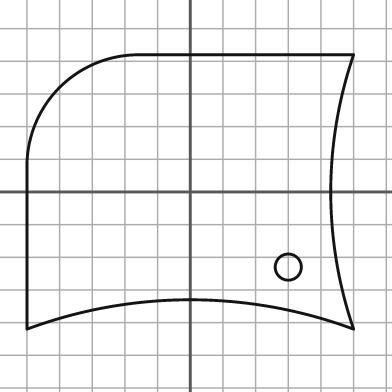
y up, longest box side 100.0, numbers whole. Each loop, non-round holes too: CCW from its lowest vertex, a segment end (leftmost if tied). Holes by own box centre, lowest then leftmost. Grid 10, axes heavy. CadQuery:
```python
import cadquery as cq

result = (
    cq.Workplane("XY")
    .moveTo(-50.0, -42.0)
    .threePointArc((0.0, -33.0), (50.0, -42.0))
    .threePointArc((43.0, 0.0), (50.0, 42.0))
    .lineTo(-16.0, 42.0)
    .threePointArc((-40.0, 32.0), (-50.0, 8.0))
    .close()
    .moveTo(30.0, -23.0)
    .circle(4.0)
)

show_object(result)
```